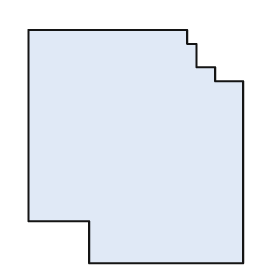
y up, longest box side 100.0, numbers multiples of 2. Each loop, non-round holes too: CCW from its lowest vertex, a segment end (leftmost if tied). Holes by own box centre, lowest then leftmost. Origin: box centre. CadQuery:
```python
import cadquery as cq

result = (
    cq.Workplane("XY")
    .moveTo(-20.0, -50.0)
    .lineTo(46.0, -50.0)
    .lineTo(46.0, 28.0)
    .lineTo(34.0, 28.0)
    .lineTo(34.0, 34.0)
    .lineTo(26.0, 34.0)
    .lineTo(26.0, 44.0)
    .lineTo(22.0, 44.0)
    .lineTo(22.0, 50.0)
    .lineTo(-46.0, 50.0)
    .lineTo(-46.0, -32.0)
    .lineTo(-20.0, -32.0)
    .close()
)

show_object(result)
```